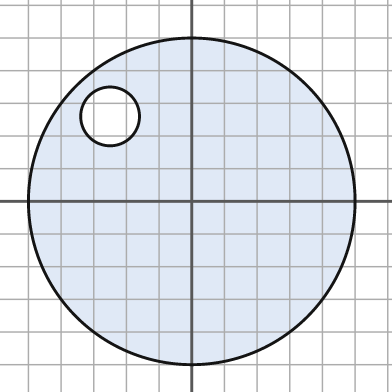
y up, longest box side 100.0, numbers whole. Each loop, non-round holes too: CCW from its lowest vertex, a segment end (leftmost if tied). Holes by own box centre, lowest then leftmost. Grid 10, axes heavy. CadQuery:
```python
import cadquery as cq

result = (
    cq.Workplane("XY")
    .moveTo(0.0, 0.0)
    .circle(50.0)
    .moveTo(-25.0, 26.0)
    .circle(9.0)
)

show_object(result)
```